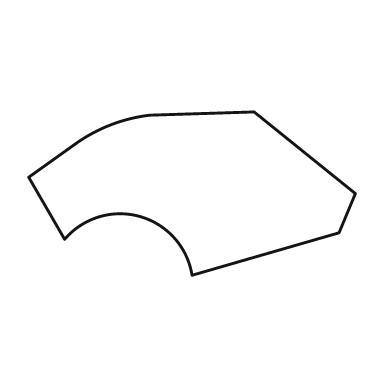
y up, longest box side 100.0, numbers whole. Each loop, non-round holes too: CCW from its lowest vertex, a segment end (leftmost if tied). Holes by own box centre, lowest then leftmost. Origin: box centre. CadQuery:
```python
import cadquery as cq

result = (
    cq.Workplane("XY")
    .moveTo(0.0, -25.0)
    .lineTo(45.0, -12.0)
    .lineTo(50.0, 0.0)
    .lineTo(19.0, 25.0)
    .lineTo(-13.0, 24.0)
    .threePointArc((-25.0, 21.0), (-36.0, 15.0))
    .lineTo(-50.0, 5.0)
    .lineTo(-39.0, -14.0)
    .threePointArc((-16.0, -7.0), (0.0, -25.0))
    .close()
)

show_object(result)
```